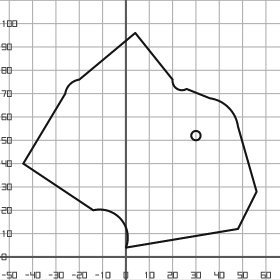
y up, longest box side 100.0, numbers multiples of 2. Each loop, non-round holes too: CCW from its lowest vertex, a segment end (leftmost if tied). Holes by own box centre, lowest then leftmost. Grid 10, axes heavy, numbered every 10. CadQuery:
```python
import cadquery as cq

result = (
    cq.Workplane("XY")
    .moveTo(0.0, 4.0)
    .lineTo(48.0, 12.0)
    .lineTo(56.0, 28.0)
    .lineTo(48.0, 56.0)
    .threePointArc((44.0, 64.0), (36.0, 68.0))
    .lineTo(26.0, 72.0)
    .threePointArc((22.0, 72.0), (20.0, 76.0))
    .lineTo(4.0, 96.0)
    .lineTo(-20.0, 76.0)
    .threePointArc((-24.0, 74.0), (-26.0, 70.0))
    .lineTo(-44.0, 40.0)
    .lineTo(-14.0, 20.0)
    .threePointArc((-2.0, 16.0), (0.0, 4.0))
    .close()
    .moveTo(30.0, 52.0)
    .circle(2.0)
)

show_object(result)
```